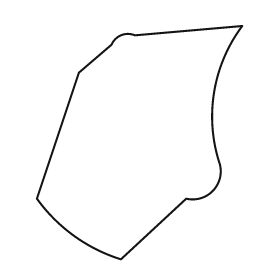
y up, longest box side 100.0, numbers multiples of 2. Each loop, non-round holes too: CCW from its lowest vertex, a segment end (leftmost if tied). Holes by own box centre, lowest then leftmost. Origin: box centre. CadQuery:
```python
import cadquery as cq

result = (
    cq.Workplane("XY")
    .moveTo(-8.0, -50.0)
    .lineTo(20.0, -24.0)
    .threePointArc((32.0, -20.0), (34.0, -8.0))
    .threePointArc((32.0, 22.0), (44.0, 50.0))
    .lineTo(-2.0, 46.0)
    .threePointArc((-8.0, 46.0), (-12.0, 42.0))
    .lineTo(-26.0, 30.0)
    .lineTo(-44.0, -24.0)
    .threePointArc((-28.0, -40.0), (-8.0, -50.0))
    .close()
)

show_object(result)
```